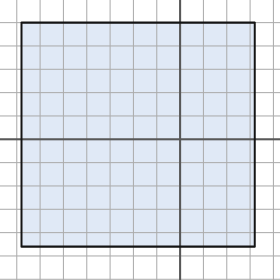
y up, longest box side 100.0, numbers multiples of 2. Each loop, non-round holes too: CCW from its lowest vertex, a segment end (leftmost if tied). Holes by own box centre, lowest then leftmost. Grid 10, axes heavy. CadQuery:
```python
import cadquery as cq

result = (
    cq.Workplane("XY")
    .moveTo(-68.0, -46.0)
    .lineTo(32.0, -46.0)
    .lineTo(32.0, 50.0)
    .lineTo(-68.0, 50.0)
    .close()
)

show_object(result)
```